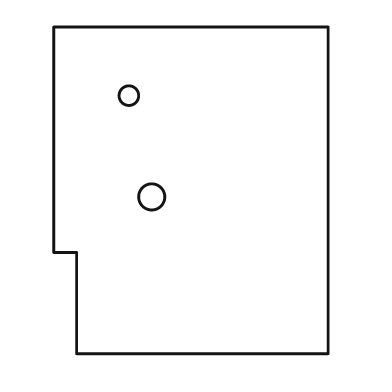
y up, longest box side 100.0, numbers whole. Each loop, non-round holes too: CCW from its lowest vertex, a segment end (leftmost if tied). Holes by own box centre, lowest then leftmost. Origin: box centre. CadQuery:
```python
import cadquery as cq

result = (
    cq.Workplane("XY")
    .moveTo(-35.0, -50.0)
    .lineTo(42.0, -50.0)
    .lineTo(42.0, 50.0)
    .lineTo(-42.0, 50.0)
    .lineTo(-42.0, -19.0)
    .lineTo(-35.0, -19.0)
    .close()
    .moveTo(-12.0, -2.0)
    .circle(4.0)
    .moveTo(-19.0, 29.0)
    .circle(3.0)
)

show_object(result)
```